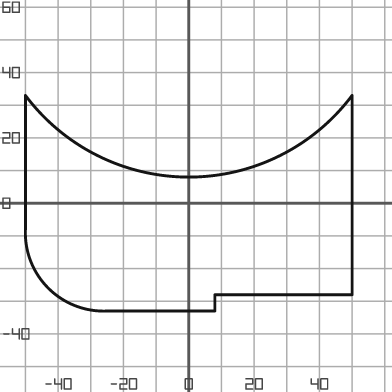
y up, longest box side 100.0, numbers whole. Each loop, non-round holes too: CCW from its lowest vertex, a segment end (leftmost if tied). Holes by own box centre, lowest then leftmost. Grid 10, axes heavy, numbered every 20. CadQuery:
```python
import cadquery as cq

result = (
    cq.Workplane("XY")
    .moveTo(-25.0, -33.0)
    .lineTo(8.0, -33.0)
    .lineTo(8.0, -28.0)
    .lineTo(50.0, -28.0)
    .lineTo(50.0, 33.0)
    .threePointArc((0.0, 8.0), (-50.0, 33.0))
    .lineTo(-50.0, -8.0)
    .threePointArc((-43.0, -26.0), (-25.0, -33.0))
    .close()
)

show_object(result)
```